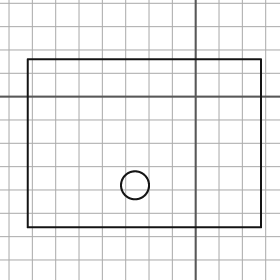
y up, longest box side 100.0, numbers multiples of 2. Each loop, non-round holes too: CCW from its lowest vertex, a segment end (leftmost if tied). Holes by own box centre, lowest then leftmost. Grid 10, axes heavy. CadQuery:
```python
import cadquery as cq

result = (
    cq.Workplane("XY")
    .moveTo(-72.0, -56.0)
    .lineTo(28.0, -56.0)
    .lineTo(28.0, 16.0)
    .lineTo(-72.0, 16.0)
    .close()
    .moveTo(-26.0, -38.0)
    .circle(6.0)
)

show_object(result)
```